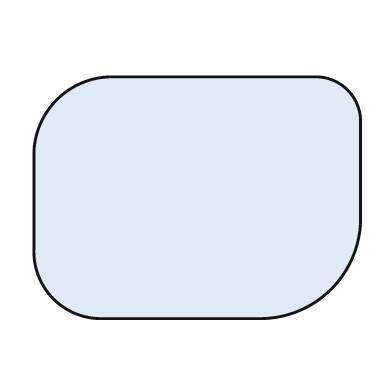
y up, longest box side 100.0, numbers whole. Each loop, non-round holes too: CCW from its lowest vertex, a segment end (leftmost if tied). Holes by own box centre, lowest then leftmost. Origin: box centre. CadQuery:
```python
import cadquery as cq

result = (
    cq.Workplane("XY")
    .moveTo(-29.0, -37.0)
    .lineTo(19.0, -37.0)
    .threePointArc((41.0, -28.0), (50.0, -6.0))
    .lineTo(50.0, 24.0)
    .threePointArc((46.0, 33.0), (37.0, 37.0))
    .lineTo(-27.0, 37.0)
    .threePointArc((-43.0, 30.0), (-50.0, 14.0))
    .lineTo(-50.0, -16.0)
    .threePointArc((-44.0, -31.0), (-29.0, -37.0))
    .close()
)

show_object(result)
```